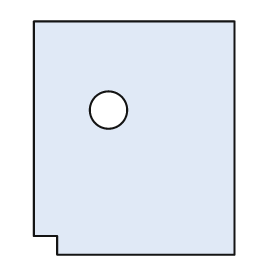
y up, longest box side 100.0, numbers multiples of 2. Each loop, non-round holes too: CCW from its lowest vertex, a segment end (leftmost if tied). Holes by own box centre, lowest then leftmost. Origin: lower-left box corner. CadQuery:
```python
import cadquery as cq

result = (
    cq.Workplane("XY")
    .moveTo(10.0, 0.0)
    .lineTo(86.0, 0.0)
    .lineTo(86.0, 100.0)
    .lineTo(0.0, 100.0)
    .lineTo(0.0, 8.0)
    .lineTo(10.0, 8.0)
    .close()
    .moveTo(32.0, 62.0)
    .circle(8.0)
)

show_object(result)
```